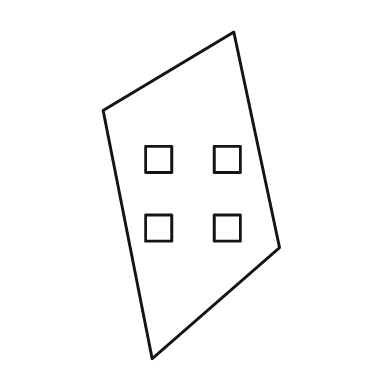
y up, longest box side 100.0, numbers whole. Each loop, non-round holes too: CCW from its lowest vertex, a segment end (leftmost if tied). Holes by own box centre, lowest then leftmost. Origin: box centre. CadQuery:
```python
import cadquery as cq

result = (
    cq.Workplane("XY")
    .moveTo(-12.0, -50.0)
    .lineTo(27.0, -16.0)
    .lineTo(13.0, 50.0)
    .lineTo(-27.0, 26.0)
    .close()
    .moveTo(-14.0, -14.0)
    .lineTo(-6.0, -14.0)
    .lineTo(-6.0, -6.0)
    .lineTo(-14.0, -6.0)
    .close()
    .moveTo(7.0, -14.0)
    .lineTo(15.0, -14.0)
    .lineTo(15.0, -6.0)
    .lineTo(7.0, -6.0)
    .close()
    .moveTo(-14.0, 7.0)
    .lineTo(-6.0, 7.0)
    .lineTo(-6.0, 15.0)
    .lineTo(-14.0, 15.0)
    .close()
    .moveTo(7.0, 7.0)
    .lineTo(15.0, 7.0)
    .lineTo(15.0, 15.0)
    .lineTo(7.0, 15.0)
    .close()
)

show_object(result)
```